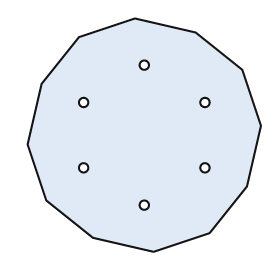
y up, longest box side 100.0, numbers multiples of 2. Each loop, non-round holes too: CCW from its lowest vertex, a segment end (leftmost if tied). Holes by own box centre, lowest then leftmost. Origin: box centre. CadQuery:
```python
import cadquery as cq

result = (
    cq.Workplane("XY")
    .moveTo(4.0, -50.0)
    .lineTo(28.0, -42.0)
    .lineTo(44.0, -22.0)
    .lineTo(50.0, 4.0)
    .lineTo(42.0, 28.0)
    .lineTo(22.0, 44.0)
    .lineTo(-4.0, 50.0)
    .lineTo(-28.0, 42.0)
    .lineTo(-44.0, 22.0)
    .lineTo(-50.0, -4.0)
    .lineTo(-42.0, -28.0)
    .lineTo(-22.0, -44.0)
    .close()
    .moveTo(0.0, -30.0)
    .circle(2.0)
    .moveTo(-26.0, -14.0)
    .circle(2.0)
    .moveTo(26.0, -14.0)
    .circle(2.0)
    .moveTo(-26.0, 14.0)
    .circle(2.0)
    .moveTo(26.0, 14.0)
    .circle(2.0)
    .moveTo(0.0, 30.0)
    .circle(2.0)
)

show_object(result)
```